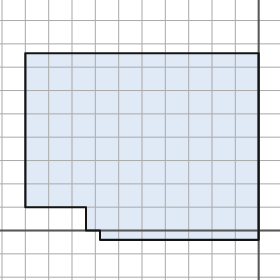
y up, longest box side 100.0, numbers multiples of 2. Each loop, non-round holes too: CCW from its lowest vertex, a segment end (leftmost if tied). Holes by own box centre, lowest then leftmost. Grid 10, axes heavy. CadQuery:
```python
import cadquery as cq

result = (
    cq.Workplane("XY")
    .moveTo(-68.0, -4.0)
    .lineTo(0.0, -4.0)
    .lineTo(0.0, 76.0)
    .lineTo(-100.0, 76.0)
    .lineTo(-100.0, 10.0)
    .lineTo(-74.0, 10.0)
    .lineTo(-74.0, 0.0)
    .lineTo(-68.0, 0.0)
    .close()
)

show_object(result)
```